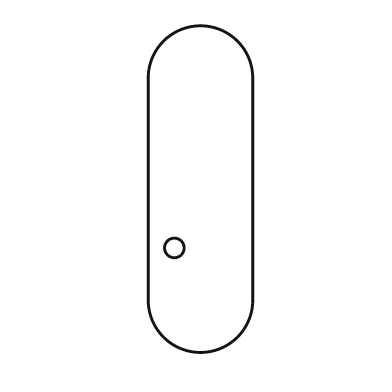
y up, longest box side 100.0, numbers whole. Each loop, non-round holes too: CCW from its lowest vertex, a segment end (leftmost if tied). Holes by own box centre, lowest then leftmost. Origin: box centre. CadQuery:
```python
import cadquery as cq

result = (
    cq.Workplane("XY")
    .moveTo(-16.0, -34.0)
    .threePointArc((0.0, -50.0), (16.0, -34.0))
    .lineTo(16.0, 34.0)
    .threePointArc((0.0, 50.0), (-16.0, 34.0))
    .close()
    .moveTo(-8.0, -18.0)
    .circle(3.0)
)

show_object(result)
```